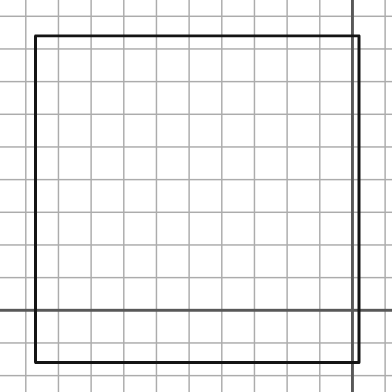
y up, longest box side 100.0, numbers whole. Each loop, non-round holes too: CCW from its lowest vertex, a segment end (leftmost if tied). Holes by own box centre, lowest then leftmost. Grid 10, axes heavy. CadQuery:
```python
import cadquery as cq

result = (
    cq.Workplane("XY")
    .moveTo(-97.0, -16.0)
    .lineTo(2.0, -16.0)
    .lineTo(2.0, 84.0)
    .lineTo(-97.0, 84.0)
    .close()
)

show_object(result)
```